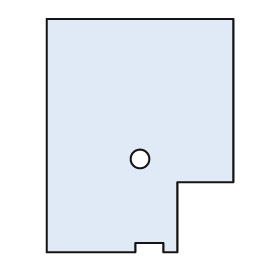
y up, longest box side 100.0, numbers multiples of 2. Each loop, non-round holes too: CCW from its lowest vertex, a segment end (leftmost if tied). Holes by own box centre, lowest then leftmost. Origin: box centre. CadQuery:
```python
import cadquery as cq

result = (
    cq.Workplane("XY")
    .moveTo(-40.0, -50.0)
    .lineTo(-2.0, -50.0)
    .lineTo(-2.0, -46.0)
    .lineTo(10.0, -46.0)
    .lineTo(10.0, -50.0)
    .lineTo(16.0, -50.0)
    .lineTo(16.0, -20.0)
    .lineTo(40.0, -20.0)
    .lineTo(40.0, 50.0)
    .lineTo(-40.0, 50.0)
    .close()
    .moveTo(0.0, -10.0)
    .circle(4.0)
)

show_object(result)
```